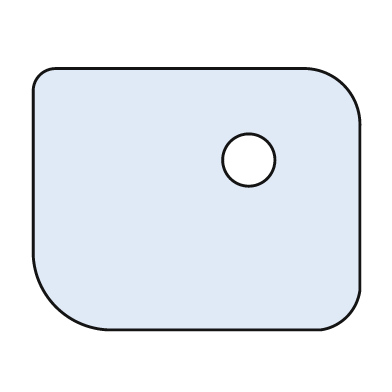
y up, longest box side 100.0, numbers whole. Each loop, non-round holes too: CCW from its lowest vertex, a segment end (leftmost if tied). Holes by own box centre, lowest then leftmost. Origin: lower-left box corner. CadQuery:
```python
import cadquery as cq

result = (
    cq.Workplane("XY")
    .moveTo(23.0, 0.0)
    .lineTo(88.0, 0.0)
    .threePointArc((96.0, 4.0), (100.0, 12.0))
    .lineTo(100.0, 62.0)
    .threePointArc((95.0, 75.0), (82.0, 80.0))
    .lineTo(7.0, 80.0)
    .threePointArc((2.0, 78.0), (0.0, 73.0))
    .lineTo(0.0, 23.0)
    .threePointArc((7.0, 7.0), (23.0, 0.0))
    .close()
    .moveTo(66.0, 52.0)
    .circle(8.0)
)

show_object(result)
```